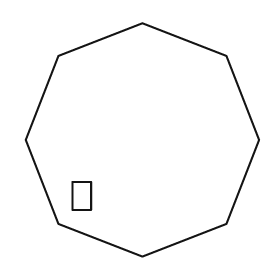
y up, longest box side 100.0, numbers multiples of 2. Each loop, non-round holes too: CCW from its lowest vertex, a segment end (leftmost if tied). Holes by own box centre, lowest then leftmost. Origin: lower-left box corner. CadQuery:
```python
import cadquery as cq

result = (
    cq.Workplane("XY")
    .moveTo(50.0, 0.0)
    .lineTo(86.0, 14.0)
    .lineTo(100.0, 50.0)
    .lineTo(86.0, 86.0)
    .lineTo(50.0, 100.0)
    .lineTo(14.0, 86.0)
    .lineTo(0.0, 50.0)
    .lineTo(14.0, 14.0)
    .close()
    .moveTo(20.0, 20.0)
    .lineTo(28.0, 20.0)
    .lineTo(28.0, 32.0)
    .lineTo(20.0, 32.0)
    .close()
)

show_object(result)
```